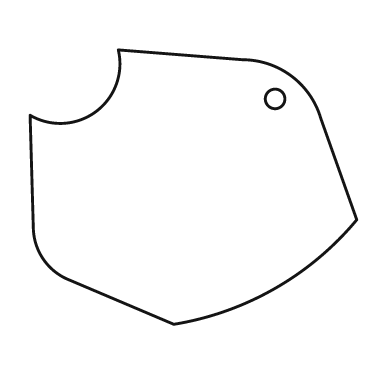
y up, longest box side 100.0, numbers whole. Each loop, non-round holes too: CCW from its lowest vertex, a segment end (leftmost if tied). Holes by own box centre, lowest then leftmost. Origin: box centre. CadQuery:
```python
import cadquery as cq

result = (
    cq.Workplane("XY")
    .moveTo(-6.0, -42.0)
    .threePointArc((25.0, -31.0), (50.0, -10.0))
    .lineTo(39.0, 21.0)
    .threePointArc((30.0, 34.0), (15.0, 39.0))
    .lineTo(-23.0, 42.0)
    .threePointArc((-30.0, 23.0), (-50.0, 22.0))
    .lineTo(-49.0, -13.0)
    .threePointArc((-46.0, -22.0), (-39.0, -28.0))
    .close()
    .moveTo(25.0, 27.0)
    .circle(3.0)
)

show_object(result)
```